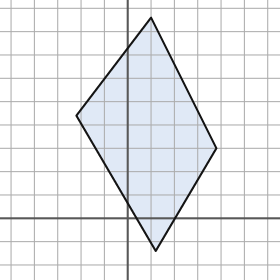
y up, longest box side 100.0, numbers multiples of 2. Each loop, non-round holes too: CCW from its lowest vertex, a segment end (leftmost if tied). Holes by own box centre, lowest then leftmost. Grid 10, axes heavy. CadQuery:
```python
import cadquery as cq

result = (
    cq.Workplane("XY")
    .moveTo(12.0, -14.0)
    .lineTo(38.0, 30.0)
    .lineTo(10.0, 86.0)
    .lineTo(-22.0, 44.0)
    .close()
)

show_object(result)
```